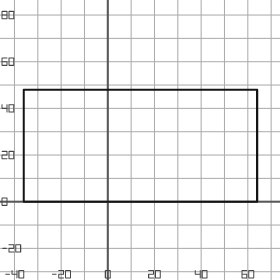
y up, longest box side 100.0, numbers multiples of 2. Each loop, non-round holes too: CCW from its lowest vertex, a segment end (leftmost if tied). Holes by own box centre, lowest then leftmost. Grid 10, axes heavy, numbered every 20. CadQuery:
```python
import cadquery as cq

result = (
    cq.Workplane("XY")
    .moveTo(-36.0, 0.0)
    .lineTo(64.0, 0.0)
    .lineTo(64.0, 48.0)
    .lineTo(-36.0, 48.0)
    .close()
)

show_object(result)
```